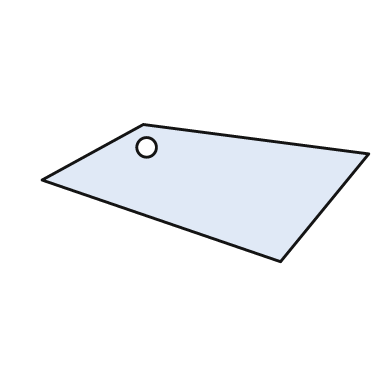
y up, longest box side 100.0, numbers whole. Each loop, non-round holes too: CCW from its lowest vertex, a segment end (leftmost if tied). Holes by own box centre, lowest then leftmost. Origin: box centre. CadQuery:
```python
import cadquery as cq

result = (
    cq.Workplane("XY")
    .moveTo(23.0, -21.0)
    .lineTo(50.0, 12.0)
    .lineTo(-19.0, 21.0)
    .lineTo(-50.0, 4.0)
    .close()
    .moveTo(-18.0, 14.0)
    .circle(3.0)
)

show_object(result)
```